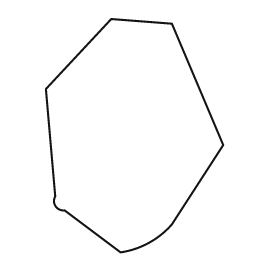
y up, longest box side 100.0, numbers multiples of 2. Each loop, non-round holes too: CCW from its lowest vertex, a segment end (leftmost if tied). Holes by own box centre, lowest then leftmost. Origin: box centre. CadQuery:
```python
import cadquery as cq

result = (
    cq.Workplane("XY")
    .moveTo(-6.0, -50.0)
    .threePointArc((6.0, -46.0), (16.0, -38.0))
    .lineTo(38.0, -4.0)
    .lineTo(16.0, 48.0)
    .lineTo(-10.0, 50.0)
    .lineTo(-38.0, 20.0)
    .lineTo(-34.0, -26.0)
    .threePointArc((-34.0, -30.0), (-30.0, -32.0))
    .close()
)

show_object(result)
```